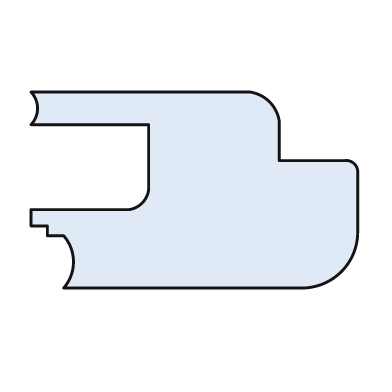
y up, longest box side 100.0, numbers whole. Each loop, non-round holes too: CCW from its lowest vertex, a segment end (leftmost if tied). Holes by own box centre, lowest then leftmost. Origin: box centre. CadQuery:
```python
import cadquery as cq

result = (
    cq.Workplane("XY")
    .moveTo(-40.0, -30.0)
    .lineTo(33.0, -30.0)
    .threePointArc((45.0, -25.0), (50.0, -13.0))
    .lineTo(50.0, 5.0)
    .threePointArc((49.0, 8.0), (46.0, 9.0))
    .lineTo(26.0, 9.0)
    .lineTo(26.0, 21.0)
    .threePointArc((23.0, 27.0), (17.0, 30.0))
    .lineTo(-50.0, 30.0)
    .threePointArc((-48.0, 25.0), (-50.0, 20.0))
    .lineTo(-14.0, 20.0)
    .lineTo(-14.0, 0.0)
    .threePointArc((-16.0, -4.0), (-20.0, -6.0))
    .lineTo(-50.0, -6.0)
    .lineTo(-50.0, -11.0)
    .lineTo(-45.0, -11.0)
    .lineTo(-45.0, -14.0)
    .lineTo(-40.0, -14.0)
    .threePointArc((-37.0, -22.0), (-40.0, -30.0))
    .close()
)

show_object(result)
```